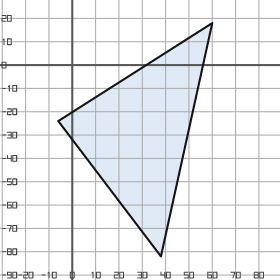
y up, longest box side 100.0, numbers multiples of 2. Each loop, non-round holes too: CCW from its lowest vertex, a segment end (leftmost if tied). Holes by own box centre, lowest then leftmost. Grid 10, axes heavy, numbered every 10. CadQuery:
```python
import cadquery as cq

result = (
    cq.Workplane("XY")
    .moveTo(38.0, -82.0)
    .lineTo(60.0, 18.0)
    .lineTo(-6.0, -24.0)
    .close()
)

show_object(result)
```